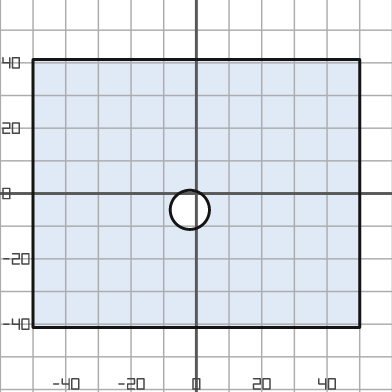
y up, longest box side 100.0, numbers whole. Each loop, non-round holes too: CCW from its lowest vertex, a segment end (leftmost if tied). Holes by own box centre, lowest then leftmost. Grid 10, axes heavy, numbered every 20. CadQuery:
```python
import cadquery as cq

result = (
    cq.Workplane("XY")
    .moveTo(-50.0, -41.0)
    .lineTo(50.0, -41.0)
    .lineTo(50.0, 41.0)
    .lineTo(-50.0, 41.0)
    .close()
    .moveTo(-2.0, -5.0)
    .circle(6.0)
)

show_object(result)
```